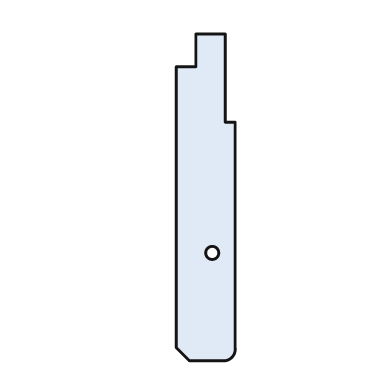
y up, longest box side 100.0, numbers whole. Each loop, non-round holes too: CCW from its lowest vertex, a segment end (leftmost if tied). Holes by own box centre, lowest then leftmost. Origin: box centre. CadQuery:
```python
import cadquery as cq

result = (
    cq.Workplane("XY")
    .moveTo(-5.0, -50.0)
    .lineTo(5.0, -50.0)
    .threePointArc((8.0, -49.0), (9.0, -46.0))
    .lineTo(9.0, 23.0)
    .lineTo(6.0, 23.0)
    .lineTo(6.0, 50.0)
    .lineTo(-3.0, 50.0)
    .lineTo(-3.0, 40.0)
    .lineTo(-9.0, 40.0)
    .lineTo(-9.0, -46.0)
    .close()
    .moveTo(2.0, -17.0)
    .circle(2.0)
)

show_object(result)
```